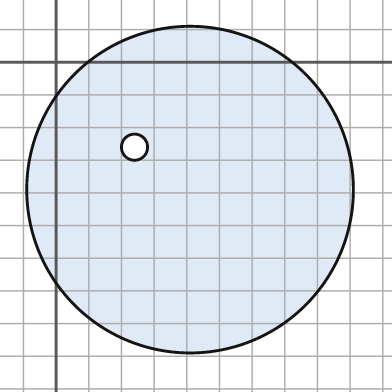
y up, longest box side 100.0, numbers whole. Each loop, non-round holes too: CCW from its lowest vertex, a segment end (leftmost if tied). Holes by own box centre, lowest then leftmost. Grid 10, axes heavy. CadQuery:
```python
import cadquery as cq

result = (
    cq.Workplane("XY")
    .moveTo(41.0, -39.0)
    .circle(50.0)
    .moveTo(24.0, -26.0)
    .circle(4.0)
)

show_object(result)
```